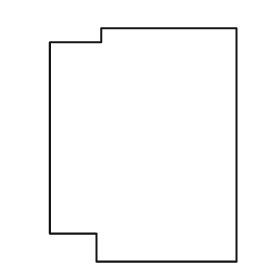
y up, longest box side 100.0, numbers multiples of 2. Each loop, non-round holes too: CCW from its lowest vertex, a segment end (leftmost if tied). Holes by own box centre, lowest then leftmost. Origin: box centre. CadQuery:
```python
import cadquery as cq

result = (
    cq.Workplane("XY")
    .moveTo(-20.0, -50.0)
    .lineTo(40.0, -50.0)
    .lineTo(40.0, 50.0)
    .lineTo(-18.0, 50.0)
    .lineTo(-18.0, 44.0)
    .lineTo(-40.0, 44.0)
    .lineTo(-40.0, -38.0)
    .lineTo(-20.0, -38.0)
    .close()
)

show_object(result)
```